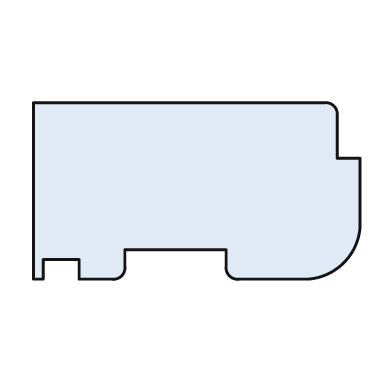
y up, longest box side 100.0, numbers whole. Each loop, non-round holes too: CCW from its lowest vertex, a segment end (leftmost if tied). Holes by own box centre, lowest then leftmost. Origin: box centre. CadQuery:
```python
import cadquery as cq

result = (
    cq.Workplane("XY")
    .moveTo(-50.0, -27.0)
    .lineTo(-47.0, -27.0)
    .lineTo(-47.0, -21.0)
    .lineTo(-36.0, -21.0)
    .lineTo(-36.0, -27.0)
    .lineTo(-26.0, -27.0)
    .threePointArc((-23.0, -26.0), (-22.0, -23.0))
    .lineTo(-22.0, -18.0)
    .lineTo(9.0, -18.0)
    .lineTo(9.0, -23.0)
    .threePointArc((10.0, -26.0), (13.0, -27.0))
    .lineTo(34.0, -27.0)
    .threePointArc((45.0, -22.0), (50.0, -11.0))
    .lineTo(50.0, 10.0)
    .lineTo(43.0, 10.0)
    .lineTo(43.0, 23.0)
    .threePointArc((42.0, 26.0), (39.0, 27.0))
    .lineTo(-50.0, 27.0)
    .close()
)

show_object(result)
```